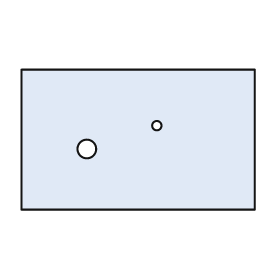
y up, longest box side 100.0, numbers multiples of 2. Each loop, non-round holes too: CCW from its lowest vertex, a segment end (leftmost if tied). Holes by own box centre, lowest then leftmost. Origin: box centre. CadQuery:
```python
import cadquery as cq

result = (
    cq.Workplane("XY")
    .moveTo(-50.0, -30.0)
    .lineTo(50.0, -30.0)
    .lineTo(50.0, 30.0)
    .lineTo(-50.0, 30.0)
    .close()
    .moveTo(-22.0, -4.0)
    .circle(4.0)
    .moveTo(8.0, 6.0)
    .circle(2.0)
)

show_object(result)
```